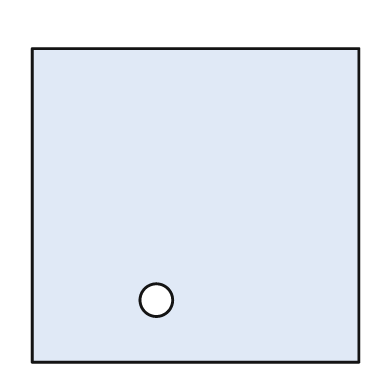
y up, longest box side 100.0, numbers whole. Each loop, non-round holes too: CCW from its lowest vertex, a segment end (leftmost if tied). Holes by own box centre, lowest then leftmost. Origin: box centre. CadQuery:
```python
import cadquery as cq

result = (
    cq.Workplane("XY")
    .moveTo(-50.0, -48.0)
    .lineTo(50.0, -48.0)
    .lineTo(50.0, 48.0)
    .lineTo(-50.0, 48.0)
    .close()
    .moveTo(-12.0, -29.0)
    .circle(5.0)
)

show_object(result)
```